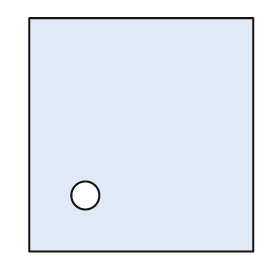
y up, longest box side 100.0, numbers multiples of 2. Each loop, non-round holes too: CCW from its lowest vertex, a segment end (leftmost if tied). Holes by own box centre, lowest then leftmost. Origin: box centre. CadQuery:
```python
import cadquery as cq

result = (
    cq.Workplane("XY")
    .moveTo(-48.0, -50.0)
    .lineTo(48.0, -50.0)
    .lineTo(48.0, 50.0)
    .lineTo(-48.0, 50.0)
    .close()
    .moveTo(-24.0, -26.0)
    .circle(6.0)
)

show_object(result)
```